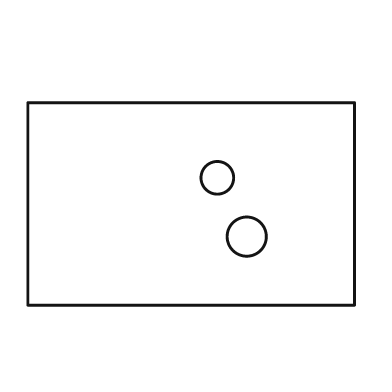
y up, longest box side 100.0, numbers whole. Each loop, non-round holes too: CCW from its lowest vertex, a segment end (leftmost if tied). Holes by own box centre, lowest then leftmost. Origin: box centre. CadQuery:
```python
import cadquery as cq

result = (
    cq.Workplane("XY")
    .moveTo(-50.0, -31.0)
    .lineTo(50.0, -31.0)
    .lineTo(50.0, 31.0)
    .lineTo(-50.0, 31.0)
    .close()
    .moveTo(17.0, -10.0)
    .circle(6.0)
    .moveTo(8.0, 8.0)
    .circle(5.0)
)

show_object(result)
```